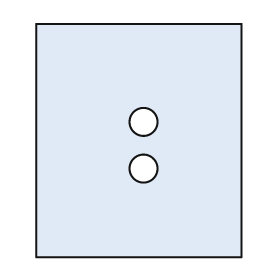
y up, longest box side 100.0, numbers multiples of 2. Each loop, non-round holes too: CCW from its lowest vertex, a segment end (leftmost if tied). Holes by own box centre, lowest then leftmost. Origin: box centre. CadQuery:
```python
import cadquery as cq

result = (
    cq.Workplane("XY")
    .moveTo(-44.0, -50.0)
    .lineTo(44.0, -50.0)
    .lineTo(44.0, 50.0)
    .lineTo(-44.0, 50.0)
    .close()
    .moveTo(2.0, -12.0)
    .circle(6.0)
    .moveTo(2.0, 8.0)
    .circle(6.0)
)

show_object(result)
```